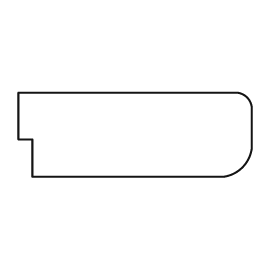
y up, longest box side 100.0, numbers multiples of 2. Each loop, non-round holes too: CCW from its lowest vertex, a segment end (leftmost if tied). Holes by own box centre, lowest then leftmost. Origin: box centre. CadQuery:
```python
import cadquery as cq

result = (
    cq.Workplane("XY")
    .moveTo(-44.0, -18.0)
    .lineTo(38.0, -18.0)
    .threePointArc((46.0, -14.0), (50.0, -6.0))
    .lineTo(50.0, 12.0)
    .threePointArc((48.0, 16.0), (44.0, 18.0))
    .lineTo(-50.0, 18.0)
    .lineTo(-50.0, -2.0)
    .lineTo(-44.0, -2.0)
    .close()
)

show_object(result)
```